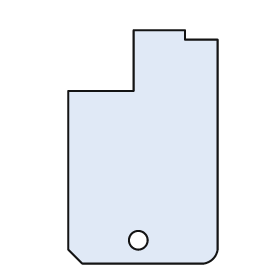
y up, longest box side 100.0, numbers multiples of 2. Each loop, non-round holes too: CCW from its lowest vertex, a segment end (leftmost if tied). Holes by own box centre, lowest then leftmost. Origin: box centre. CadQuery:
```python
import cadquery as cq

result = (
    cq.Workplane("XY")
    .moveTo(-26.0, -50.0)
    .lineTo(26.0, -50.0)
    .threePointArc((30.0, -48.0), (32.0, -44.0))
    .lineTo(32.0, 46.0)
    .lineTo(18.0, 46.0)
    .lineTo(18.0, 50.0)
    .lineTo(-4.0, 50.0)
    .lineTo(-4.0, 24.0)
    .lineTo(-32.0, 24.0)
    .lineTo(-32.0, -44.0)
    .close()
    .moveTo(-2.0, -40.0)
    .circle(4.0)
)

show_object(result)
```